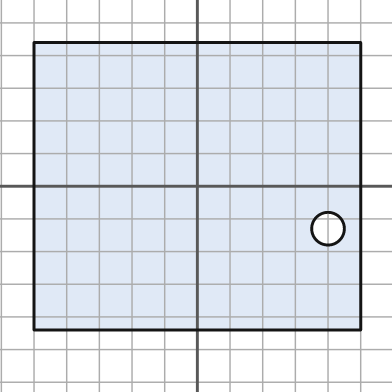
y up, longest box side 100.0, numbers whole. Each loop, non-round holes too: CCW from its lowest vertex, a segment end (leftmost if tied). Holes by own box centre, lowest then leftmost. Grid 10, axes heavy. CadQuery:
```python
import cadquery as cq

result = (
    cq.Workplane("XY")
    .moveTo(-50.0, -44.0)
    .lineTo(50.0, -44.0)
    .lineTo(50.0, 44.0)
    .lineTo(-50.0, 44.0)
    .close()
    .moveTo(40.0, -13.0)
    .circle(5.0)
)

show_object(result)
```